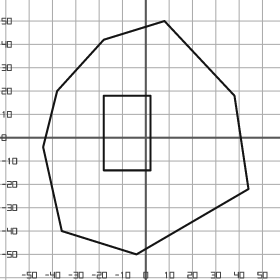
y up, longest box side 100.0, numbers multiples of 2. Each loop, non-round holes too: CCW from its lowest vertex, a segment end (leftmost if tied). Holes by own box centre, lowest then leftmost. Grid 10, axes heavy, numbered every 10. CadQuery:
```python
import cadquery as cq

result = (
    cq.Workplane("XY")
    .moveTo(-4.0, -50.0)
    .lineTo(44.0, -22.0)
    .lineTo(38.0, 18.0)
    .lineTo(8.0, 50.0)
    .lineTo(-18.0, 42.0)
    .lineTo(-38.0, 20.0)
    .lineTo(-44.0, -4.0)
    .lineTo(-36.0, -40.0)
    .close()
    .moveTo(-18.0, -14.0)
    .lineTo(2.0, -14.0)
    .lineTo(2.0, 18.0)
    .lineTo(-18.0, 18.0)
    .close()
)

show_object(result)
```